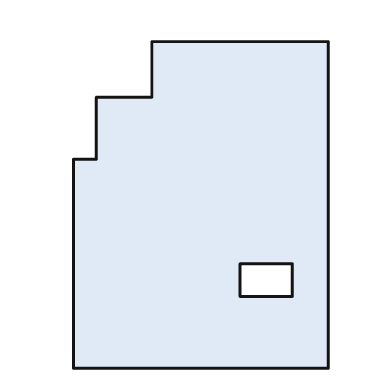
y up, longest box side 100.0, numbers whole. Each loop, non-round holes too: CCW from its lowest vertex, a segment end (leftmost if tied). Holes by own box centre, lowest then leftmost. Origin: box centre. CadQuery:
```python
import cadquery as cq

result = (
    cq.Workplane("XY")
    .moveTo(-39.0, -50.0)
    .lineTo(39.0, -50.0)
    .lineTo(39.0, 50.0)
    .lineTo(-15.0, 50.0)
    .lineTo(-15.0, 33.0)
    .lineTo(-32.0, 33.0)
    .lineTo(-32.0, 14.0)
    .lineTo(-39.0, 14.0)
    .close()
    .moveTo(12.0, -28.0)
    .lineTo(28.0, -28.0)
    .lineTo(28.0, -18.0)
    .lineTo(12.0, -18.0)
    .close()
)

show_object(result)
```